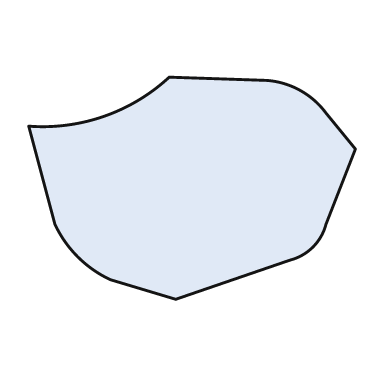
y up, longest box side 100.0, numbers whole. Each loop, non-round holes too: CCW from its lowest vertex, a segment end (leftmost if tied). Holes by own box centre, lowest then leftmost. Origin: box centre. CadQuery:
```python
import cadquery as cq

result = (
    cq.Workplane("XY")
    .moveTo(-5.0, -34.0)
    .lineTo(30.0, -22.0)
    .threePointArc((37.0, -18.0), (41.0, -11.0))
    .lineTo(50.0, 12.0)
    .lineTo(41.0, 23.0)
    .threePointArc((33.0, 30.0), (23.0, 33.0))
    .lineTo(-7.0, 34.0)
    .threePointArc((-27.0, 22.0), (-50.0, 19.0))
    .lineTo(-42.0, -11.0)
    .threePointArc((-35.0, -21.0), (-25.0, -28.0))
    .close()
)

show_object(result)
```